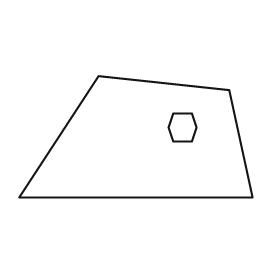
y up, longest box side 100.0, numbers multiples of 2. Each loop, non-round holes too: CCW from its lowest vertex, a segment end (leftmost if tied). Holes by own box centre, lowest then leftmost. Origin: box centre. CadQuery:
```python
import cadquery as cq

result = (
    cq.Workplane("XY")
    .moveTo(-50.0, -26.0)
    .lineTo(50.0, -26.0)
    .lineTo(40.0, 20.0)
    .lineTo(-16.0, 26.0)
    .close()
    .moveTo(16.0, -2.0)
    .lineTo(24.0, -2.0)
    .lineTo(26.0, 4.0)
    .lineTo(24.0, 10.0)
    .lineTo(16.0, 10.0)
    .lineTo(14.0, 4.0)
    .close()
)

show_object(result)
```